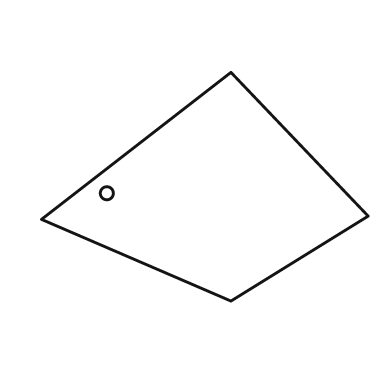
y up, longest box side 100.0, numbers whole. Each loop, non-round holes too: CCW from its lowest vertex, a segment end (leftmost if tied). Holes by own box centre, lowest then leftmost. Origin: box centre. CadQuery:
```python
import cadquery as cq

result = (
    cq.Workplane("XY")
    .moveTo(8.0, -35.0)
    .lineTo(50.0, -9.0)
    .lineTo(8.0, 35.0)
    .lineTo(-50.0, -10.0)
    .close()
    .moveTo(-30.0, -2.0)
    .circle(2.0)
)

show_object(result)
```